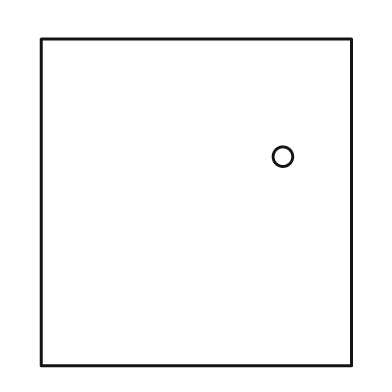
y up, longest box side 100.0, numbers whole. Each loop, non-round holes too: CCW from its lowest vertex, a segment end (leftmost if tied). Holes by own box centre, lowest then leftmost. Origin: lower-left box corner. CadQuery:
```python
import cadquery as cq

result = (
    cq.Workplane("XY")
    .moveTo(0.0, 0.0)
    .lineTo(95.0, 0.0)
    .lineTo(95.0, 100.0)
    .lineTo(0.0, 100.0)
    .close()
    .moveTo(74.0, 64.0)
    .circle(3.0)
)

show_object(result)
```